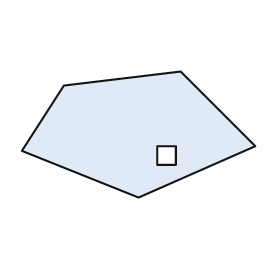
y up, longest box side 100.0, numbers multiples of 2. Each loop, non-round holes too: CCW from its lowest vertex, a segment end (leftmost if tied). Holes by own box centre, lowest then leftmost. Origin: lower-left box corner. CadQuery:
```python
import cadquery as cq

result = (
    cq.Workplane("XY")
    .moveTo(50.0, 0.0)
    .lineTo(100.0, 22.0)
    .lineTo(68.0, 54.0)
    .lineTo(18.0, 48.0)
    .lineTo(0.0, 20.0)
    .close()
    .moveTo(58.0, 14.0)
    .lineTo(66.0, 14.0)
    .lineTo(66.0, 22.0)
    .lineTo(58.0, 22.0)
    .close()
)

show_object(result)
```